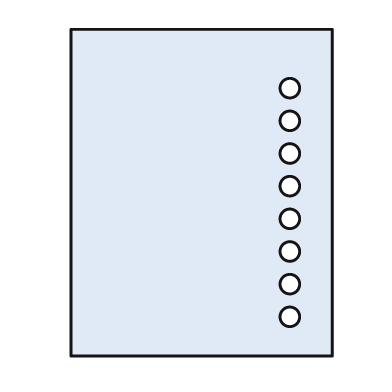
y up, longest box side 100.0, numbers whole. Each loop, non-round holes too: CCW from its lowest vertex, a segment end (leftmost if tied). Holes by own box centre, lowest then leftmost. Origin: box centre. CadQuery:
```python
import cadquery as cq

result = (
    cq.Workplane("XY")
    .moveTo(-40.0, -50.0)
    .lineTo(40.0, -50.0)
    .lineTo(40.0, 50.0)
    .lineTo(-40.0, 50.0)
    .close()
    .moveTo(27.0, -38.0)
    .circle(3.0)
    .moveTo(27.0, -28.0)
    .circle(3.0)
    .moveTo(27.0, -18.0)
    .circle(3.0)
    .moveTo(27.0, -8.0)
    .circle(3.0)
    .moveTo(27.0, 2.0)
    .circle(3.0)
    .moveTo(27.0, 12.0)
    .circle(3.0)
    .moveTo(27.0, 22.0)
    .circle(3.0)
    .moveTo(27.0, 32.0)
    .circle(3.0)
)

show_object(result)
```